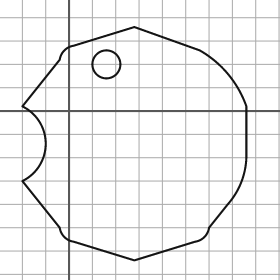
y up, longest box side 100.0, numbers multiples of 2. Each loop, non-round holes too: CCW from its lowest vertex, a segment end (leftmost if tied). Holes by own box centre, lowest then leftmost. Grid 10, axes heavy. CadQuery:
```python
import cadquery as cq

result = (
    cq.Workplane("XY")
    .moveTo(28.0, -64.0)
    .lineTo(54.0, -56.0)
    .threePointArc((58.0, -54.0), (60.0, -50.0))
    .lineTo(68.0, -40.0)
    .threePointArc((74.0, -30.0), (76.0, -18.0))
    .lineTo(76.0, 2.0)
    .threePointArc((68.0, 16.0), (56.0, 26.0))
    .lineTo(28.0, 36.0)
    .lineTo(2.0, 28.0)
    .threePointArc((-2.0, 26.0), (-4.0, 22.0))
    .lineTo(-20.0, 2.0)
    .threePointArc((-10.0, -14.0), (-20.0, -30.0))
    .lineTo(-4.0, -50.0)
    .threePointArc((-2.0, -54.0), (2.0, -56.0))
    .close()
    .moveTo(16.0, 20.0)
    .circle(6.0)
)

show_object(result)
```